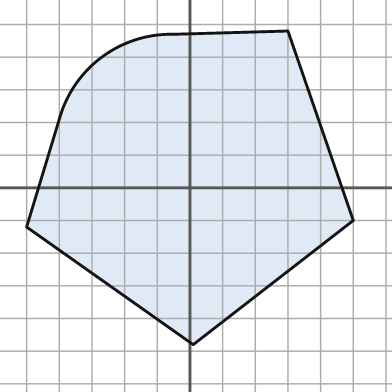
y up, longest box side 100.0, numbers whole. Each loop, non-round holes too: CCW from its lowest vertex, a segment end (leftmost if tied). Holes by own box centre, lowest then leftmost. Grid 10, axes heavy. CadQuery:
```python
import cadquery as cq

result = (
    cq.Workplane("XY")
    .moveTo(1.0, -48.0)
    .lineTo(50.0, -10.0)
    .lineTo(30.0, 48.0)
    .lineTo(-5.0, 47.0)
    .threePointArc((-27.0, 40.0), (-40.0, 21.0))
    .lineTo(-50.0, -12.0)
    .close()
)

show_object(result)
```